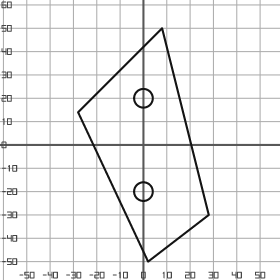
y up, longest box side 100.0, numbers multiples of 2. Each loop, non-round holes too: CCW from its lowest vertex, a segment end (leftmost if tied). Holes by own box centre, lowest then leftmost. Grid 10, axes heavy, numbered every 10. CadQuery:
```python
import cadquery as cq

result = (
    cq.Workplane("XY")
    .moveTo(2.0, -50.0)
    .lineTo(28.0, -30.0)
    .lineTo(8.0, 50.0)
    .lineTo(-28.0, 14.0)
    .close()
    .moveTo(0.0, -20.0)
    .circle(4.0)
    .moveTo(0.0, 20.0)
    .circle(4.0)
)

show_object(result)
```